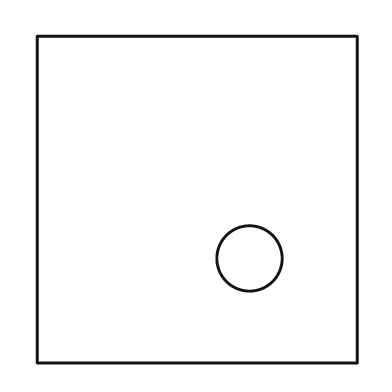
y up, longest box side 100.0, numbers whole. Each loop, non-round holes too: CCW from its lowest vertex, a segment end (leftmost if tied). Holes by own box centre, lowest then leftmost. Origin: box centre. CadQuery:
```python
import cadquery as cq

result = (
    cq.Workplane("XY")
    .moveTo(-49.0, -50.0)
    .lineTo(49.0, -50.0)
    .lineTo(49.0, 50.0)
    .lineTo(-49.0, 50.0)
    .close()
    .moveTo(16.0, -18.0)
    .circle(10.0)
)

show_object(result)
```